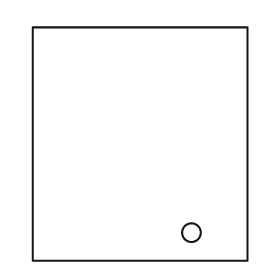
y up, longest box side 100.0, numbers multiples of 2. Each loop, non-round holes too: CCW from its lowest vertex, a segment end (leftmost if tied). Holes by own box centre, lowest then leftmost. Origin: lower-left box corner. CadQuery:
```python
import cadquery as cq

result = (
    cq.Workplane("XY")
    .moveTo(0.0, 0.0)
    .lineTo(92.0, 0.0)
    .lineTo(92.0, 100.0)
    .lineTo(0.0, 100.0)
    .close()
    .moveTo(68.0, 12.0)
    .circle(4.0)
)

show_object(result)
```